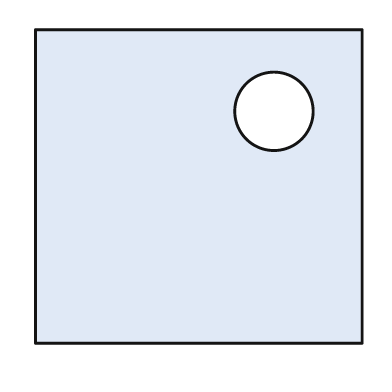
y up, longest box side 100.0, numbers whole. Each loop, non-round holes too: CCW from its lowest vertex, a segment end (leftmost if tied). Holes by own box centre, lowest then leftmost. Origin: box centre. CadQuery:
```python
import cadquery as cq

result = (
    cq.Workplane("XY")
    .moveTo(-50.0, -48.0)
    .lineTo(50.0, -48.0)
    .lineTo(50.0, 48.0)
    .lineTo(-50.0, 48.0)
    .close()
    .moveTo(23.0, 23.0)
    .circle(12.0)
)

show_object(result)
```